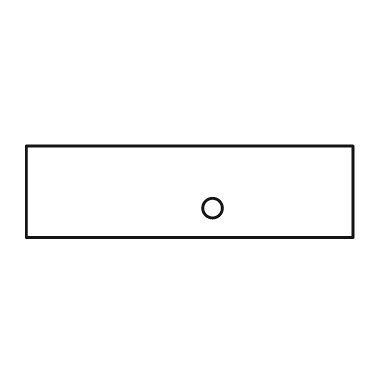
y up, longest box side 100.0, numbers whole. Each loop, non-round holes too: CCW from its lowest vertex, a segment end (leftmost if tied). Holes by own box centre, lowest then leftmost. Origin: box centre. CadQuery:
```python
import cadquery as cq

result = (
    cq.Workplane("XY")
    .moveTo(-50.0, -14.0)
    .lineTo(50.0, -14.0)
    .lineTo(50.0, 14.0)
    .lineTo(-50.0, 14.0)
    .close()
    .moveTo(7.0, -5.0)
    .circle(3.0)
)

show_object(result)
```